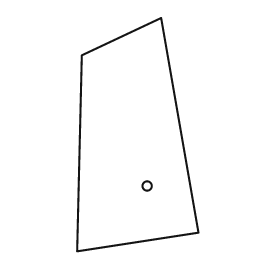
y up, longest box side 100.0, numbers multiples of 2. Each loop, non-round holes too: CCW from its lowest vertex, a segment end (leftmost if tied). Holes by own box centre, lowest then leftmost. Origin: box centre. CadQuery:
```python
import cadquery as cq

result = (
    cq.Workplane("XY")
    .moveTo(-26.0, -50.0)
    .lineTo(26.0, -42.0)
    .lineTo(10.0, 50.0)
    .lineTo(-24.0, 34.0)
    .close()
    .moveTo(4.0, -22.0)
    .circle(2.0)
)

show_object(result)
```